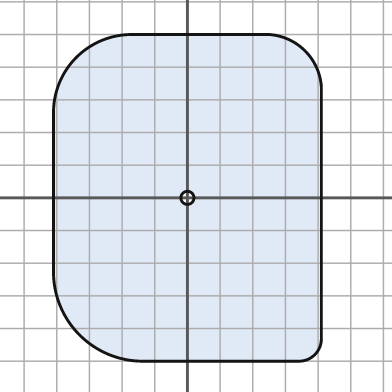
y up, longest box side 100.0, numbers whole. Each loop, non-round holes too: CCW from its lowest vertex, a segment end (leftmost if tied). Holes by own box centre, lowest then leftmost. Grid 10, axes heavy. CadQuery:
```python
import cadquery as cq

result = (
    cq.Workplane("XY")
    .moveTo(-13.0, -50.0)
    .lineTo(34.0, -50.0)
    .threePointArc((39.0, -48.0), (41.0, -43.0))
    .lineTo(41.0, 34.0)
    .threePointArc((36.0, 45.0), (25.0, 50.0))
    .lineTo(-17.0, 50.0)
    .threePointArc((-34.0, 43.0), (-41.0, 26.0))
    .lineTo(-41.0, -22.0)
    .threePointArc((-33.0, -42.0), (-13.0, -50.0))
    .close()
    .moveTo(0.0, 0.0)
    .circle(2.0)
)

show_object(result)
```